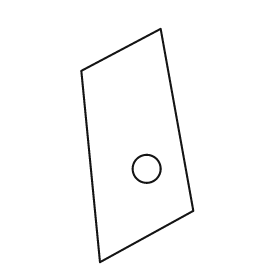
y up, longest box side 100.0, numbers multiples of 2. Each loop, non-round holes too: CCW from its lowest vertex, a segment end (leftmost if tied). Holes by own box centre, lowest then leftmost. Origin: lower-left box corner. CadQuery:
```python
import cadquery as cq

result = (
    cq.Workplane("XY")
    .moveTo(8.0, 0.0)
    .lineTo(48.0, 22.0)
    .lineTo(34.0, 100.0)
    .lineTo(0.0, 82.0)
    .close()
    .moveTo(28.0, 40.0)
    .circle(6.0)
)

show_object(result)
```